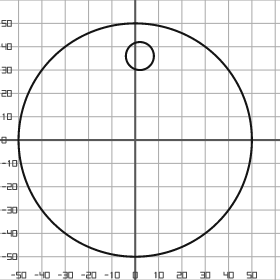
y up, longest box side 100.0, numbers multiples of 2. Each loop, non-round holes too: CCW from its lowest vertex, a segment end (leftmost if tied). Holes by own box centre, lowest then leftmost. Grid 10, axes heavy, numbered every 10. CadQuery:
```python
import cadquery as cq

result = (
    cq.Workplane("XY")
    .moveTo(0.0, 0.0)
    .circle(50.0)
    .moveTo(2.0, 36.0)
    .circle(6.0)
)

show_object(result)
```